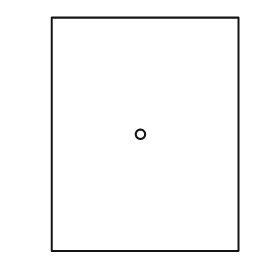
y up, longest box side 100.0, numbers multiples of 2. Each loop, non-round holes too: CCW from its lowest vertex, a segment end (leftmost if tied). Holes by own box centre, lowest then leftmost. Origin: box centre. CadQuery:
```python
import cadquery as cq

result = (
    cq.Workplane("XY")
    .moveTo(-40.0, -50.0)
    .lineTo(40.0, -50.0)
    .lineTo(40.0, 50.0)
    .lineTo(-40.0, 50.0)
    .close()
    .moveTo(-2.0, 0.0)
    .circle(2.0)
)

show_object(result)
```